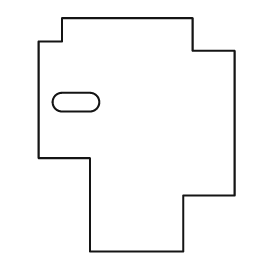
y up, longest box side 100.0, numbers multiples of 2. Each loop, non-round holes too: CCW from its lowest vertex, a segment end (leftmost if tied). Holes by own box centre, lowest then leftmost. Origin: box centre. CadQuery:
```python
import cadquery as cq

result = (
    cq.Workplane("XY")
    .moveTo(-20.0, -50.0)
    .lineTo(20.0, -50.0)
    .lineTo(20.0, -26.0)
    .lineTo(42.0, -26.0)
    .lineTo(42.0, 36.0)
    .lineTo(24.0, 36.0)
    .lineTo(24.0, 50.0)
    .lineTo(-32.0, 50.0)
    .lineTo(-32.0, 40.0)
    .lineTo(-42.0, 40.0)
    .lineTo(-42.0, -10.0)
    .lineTo(-20.0, -10.0)
    .close()
    .moveTo(-32.0, 10.0)
    .lineTo(-20.0, 10.0)
    .threePointArc((-16.0, 14.0), (-20.0, 18.0))
    .lineTo(-32.0, 18.0)
    .threePointArc((-36.0, 14.0), (-32.0, 10.0))
    .close()
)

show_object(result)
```